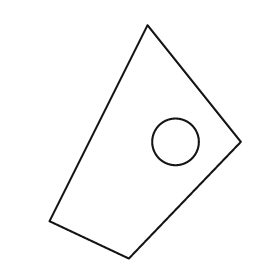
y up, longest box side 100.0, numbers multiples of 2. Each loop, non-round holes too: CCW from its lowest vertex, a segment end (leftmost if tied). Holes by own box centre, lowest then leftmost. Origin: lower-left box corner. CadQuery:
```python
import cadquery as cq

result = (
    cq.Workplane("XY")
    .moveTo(34.0, 0.0)
    .lineTo(82.0, 50.0)
    .lineTo(42.0, 100.0)
    .lineTo(0.0, 16.0)
    .close()
    .moveTo(54.0, 50.0)
    .circle(10.0)
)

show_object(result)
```